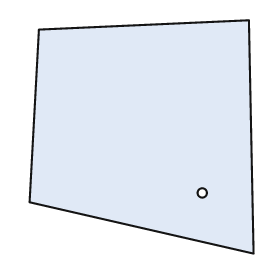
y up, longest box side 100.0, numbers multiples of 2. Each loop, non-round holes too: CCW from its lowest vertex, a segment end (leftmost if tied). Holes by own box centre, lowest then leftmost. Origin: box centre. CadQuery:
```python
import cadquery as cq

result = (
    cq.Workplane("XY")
    .moveTo(48.0, -50.0)
    .lineTo(46.0, 50.0)
    .lineTo(-44.0, 46.0)
    .lineTo(-48.0, -28.0)
    .close()
    .moveTo(26.0, -24.0)
    .circle(2.0)
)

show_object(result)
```